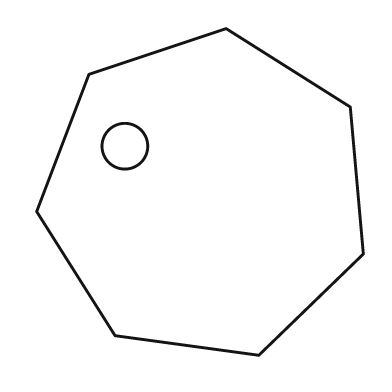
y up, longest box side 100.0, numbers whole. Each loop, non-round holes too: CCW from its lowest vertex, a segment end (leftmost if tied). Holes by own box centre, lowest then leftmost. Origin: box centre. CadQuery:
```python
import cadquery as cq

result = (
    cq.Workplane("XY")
    .moveTo(18.0, -50.0)
    .lineTo(50.0, -19.0)
    .lineTo(46.0, 26.0)
    .lineTo(8.0, 50.0)
    .lineTo(-34.0, 36.0)
    .lineTo(-50.0, -6.0)
    .lineTo(-26.0, -44.0)
    .close()
    .moveTo(-23.0, 14.0)
    .circle(7.0)
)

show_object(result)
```